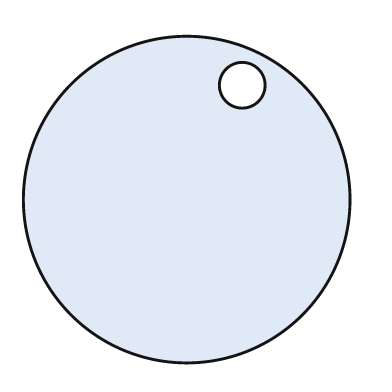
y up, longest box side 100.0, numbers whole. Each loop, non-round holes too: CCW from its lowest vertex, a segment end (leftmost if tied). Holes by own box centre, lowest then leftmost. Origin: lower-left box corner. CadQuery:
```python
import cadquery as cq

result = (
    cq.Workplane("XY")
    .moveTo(50.0, 50.0)
    .circle(50.0)
    .moveTo(67.0, 85.0)
    .circle(7.0)
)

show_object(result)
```